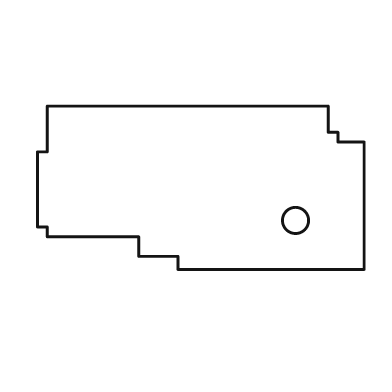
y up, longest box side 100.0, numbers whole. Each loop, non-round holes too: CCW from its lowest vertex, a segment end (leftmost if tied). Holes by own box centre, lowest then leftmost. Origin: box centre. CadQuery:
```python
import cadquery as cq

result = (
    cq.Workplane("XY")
    .moveTo(-7.0, -25.0)
    .lineTo(50.0, -25.0)
    .lineTo(50.0, 14.0)
    .lineTo(42.0, 14.0)
    .lineTo(42.0, 17.0)
    .lineTo(39.0, 17.0)
    .lineTo(39.0, 25.0)
    .lineTo(-47.0, 25.0)
    .lineTo(-47.0, 11.0)
    .lineTo(-50.0, 11.0)
    .lineTo(-50.0, -12.0)
    .lineTo(-47.0, -12.0)
    .lineTo(-47.0, -15.0)
    .lineTo(-19.0, -15.0)
    .lineTo(-19.0, -21.0)
    .lineTo(-7.0, -21.0)
    .close()
    .moveTo(29.0, -10.0)
    .circle(4.0)
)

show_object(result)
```